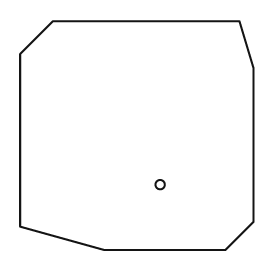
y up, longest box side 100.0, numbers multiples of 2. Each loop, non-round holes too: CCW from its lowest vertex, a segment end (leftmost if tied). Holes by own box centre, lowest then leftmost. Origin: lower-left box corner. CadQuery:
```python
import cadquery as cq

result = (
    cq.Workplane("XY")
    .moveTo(36.0, 0.0)
    .lineTo(88.0, 0.0)
    .lineTo(100.0, 12.0)
    .lineTo(100.0, 78.0)
    .lineTo(94.0, 98.0)
    .lineTo(14.0, 98.0)
    .lineTo(0.0, 84.0)
    .lineTo(0.0, 10.0)
    .close()
    .moveTo(60.0, 28.0)
    .circle(2.0)
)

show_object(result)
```